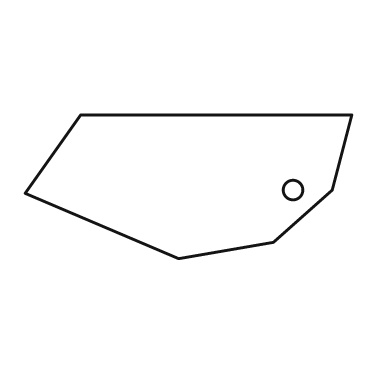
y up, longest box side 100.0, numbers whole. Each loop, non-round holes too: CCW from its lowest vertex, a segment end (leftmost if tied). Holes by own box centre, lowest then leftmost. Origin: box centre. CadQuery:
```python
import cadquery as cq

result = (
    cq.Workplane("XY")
    .moveTo(-3.0, -22.0)
    .lineTo(26.0, -17.0)
    .lineTo(44.0, -1.0)
    .lineTo(50.0, 22.0)
    .lineTo(-33.0, 22.0)
    .lineTo(-50.0, -2.0)
    .close()
    .moveTo(32.0, -1.0)
    .circle(3.0)
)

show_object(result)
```